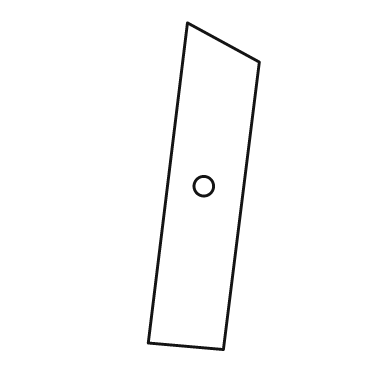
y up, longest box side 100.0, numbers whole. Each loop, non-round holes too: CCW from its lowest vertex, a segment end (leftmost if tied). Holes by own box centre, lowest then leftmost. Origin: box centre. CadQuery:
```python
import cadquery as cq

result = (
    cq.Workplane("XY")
    .moveTo(6.0, -50.0)
    .lineTo(17.0, 38.0)
    .lineTo(-5.0, 50.0)
    .lineTo(-17.0, -48.0)
    .close()
    .moveTo(0.0, 0.0)
    .circle(3.0)
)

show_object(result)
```